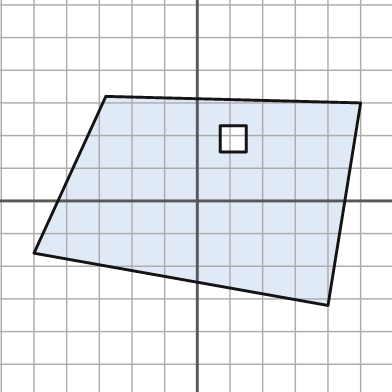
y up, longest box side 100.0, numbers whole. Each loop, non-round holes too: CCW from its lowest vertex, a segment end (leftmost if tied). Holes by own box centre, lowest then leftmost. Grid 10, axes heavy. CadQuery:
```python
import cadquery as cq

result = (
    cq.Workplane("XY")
    .moveTo(40.0, -32.0)
    .lineTo(50.0, 30.0)
    .lineTo(-28.0, 32.0)
    .lineTo(-50.0, -16.0)
    .close()
    .moveTo(7.0, 15.0)
    .lineTo(15.0, 15.0)
    .lineTo(15.0, 23.0)
    .lineTo(7.0, 23.0)
    .close()
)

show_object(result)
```